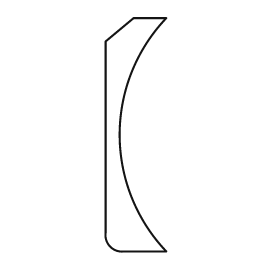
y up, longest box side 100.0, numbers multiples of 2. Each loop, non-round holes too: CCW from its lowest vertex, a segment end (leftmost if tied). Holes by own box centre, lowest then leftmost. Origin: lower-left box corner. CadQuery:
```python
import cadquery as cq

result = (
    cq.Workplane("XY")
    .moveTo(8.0, 0.0)
    .lineTo(26.0, 0.0)
    .threePointArc((6.0, 50.0), (26.0, 100.0))
    .lineTo(12.0, 100.0)
    .lineTo(0.0, 90.0)
    .lineTo(0.0, 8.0)
    .threePointArc((2.0, 2.0), (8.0, 0.0))
    .close()
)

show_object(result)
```